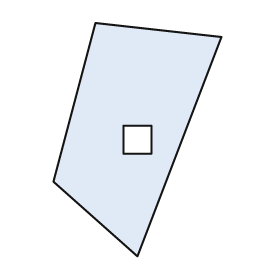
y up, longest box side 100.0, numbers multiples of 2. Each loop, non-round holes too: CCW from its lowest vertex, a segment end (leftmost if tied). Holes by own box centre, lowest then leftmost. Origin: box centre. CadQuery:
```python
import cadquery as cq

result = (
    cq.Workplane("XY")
    .moveTo(0.0, -50.0)
    .lineTo(36.0, 44.0)
    .lineTo(-18.0, 50.0)
    .lineTo(-36.0, -18.0)
    .close()
    .moveTo(-6.0, -6.0)
    .lineTo(6.0, -6.0)
    .lineTo(6.0, 6.0)
    .lineTo(-6.0, 6.0)
    .close()
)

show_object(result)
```